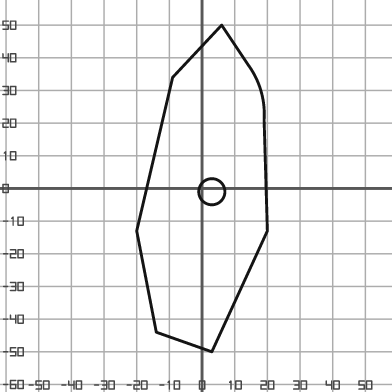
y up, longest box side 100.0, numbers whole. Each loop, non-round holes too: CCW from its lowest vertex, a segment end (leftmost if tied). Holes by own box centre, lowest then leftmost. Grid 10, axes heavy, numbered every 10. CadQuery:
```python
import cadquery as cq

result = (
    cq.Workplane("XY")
    .moveTo(3.0, -50.0)
    .lineTo(20.0, -13.0)
    .lineTo(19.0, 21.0)
    .threePointArc((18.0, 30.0), (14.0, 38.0))
    .lineTo(6.0, 50.0)
    .lineTo(-9.0, 34.0)
    .lineTo(-20.0, -13.0)
    .lineTo(-14.0, -44.0)
    .close()
    .moveTo(3.0, -1.0)
    .circle(4.0)
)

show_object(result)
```